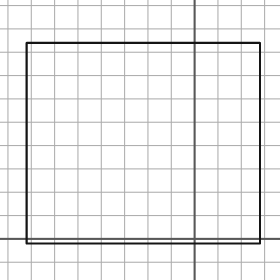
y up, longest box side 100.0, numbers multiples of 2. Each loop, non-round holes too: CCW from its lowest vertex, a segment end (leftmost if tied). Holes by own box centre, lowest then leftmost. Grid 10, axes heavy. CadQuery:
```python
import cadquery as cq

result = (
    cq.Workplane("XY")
    .moveTo(-72.0, -2.0)
    .lineTo(28.0, -2.0)
    .lineTo(28.0, 84.0)
    .lineTo(-72.0, 84.0)
    .close()
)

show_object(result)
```